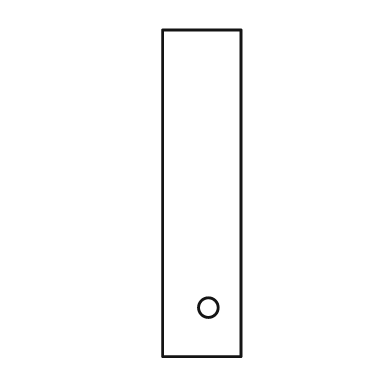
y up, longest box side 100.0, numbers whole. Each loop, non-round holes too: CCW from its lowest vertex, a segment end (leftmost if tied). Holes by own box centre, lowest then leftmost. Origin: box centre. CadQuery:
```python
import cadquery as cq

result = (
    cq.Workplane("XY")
    .moveTo(-12.0, -50.0)
    .lineTo(12.0, -50.0)
    .lineTo(12.0, 50.0)
    .lineTo(-12.0, 50.0)
    .close()
    .moveTo(2.0, -35.0)
    .circle(3.0)
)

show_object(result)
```